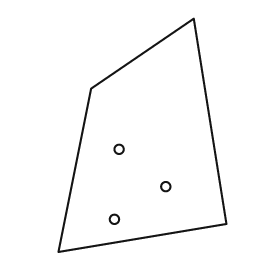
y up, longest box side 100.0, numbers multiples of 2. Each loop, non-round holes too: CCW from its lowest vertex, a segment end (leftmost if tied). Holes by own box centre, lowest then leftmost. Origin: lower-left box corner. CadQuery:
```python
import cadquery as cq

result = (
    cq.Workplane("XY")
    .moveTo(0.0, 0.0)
    .lineTo(72.0, 12.0)
    .lineTo(58.0, 100.0)
    .lineTo(14.0, 70.0)
    .close()
    .moveTo(24.0, 14.0)
    .circle(2.0)
    .moveTo(46.0, 28.0)
    .circle(2.0)
    .moveTo(26.0, 44.0)
    .circle(2.0)
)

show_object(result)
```